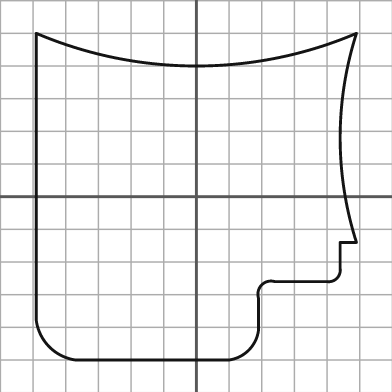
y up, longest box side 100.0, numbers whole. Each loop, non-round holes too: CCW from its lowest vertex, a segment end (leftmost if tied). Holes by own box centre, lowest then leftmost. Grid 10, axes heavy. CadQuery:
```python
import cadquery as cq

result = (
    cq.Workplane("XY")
    .moveTo(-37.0, -50.0)
    .lineTo(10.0, -50.0)
    .threePointArc((16.0, -47.0), (19.0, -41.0))
    .lineTo(19.0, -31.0)
    .threePointArc((20.0, -27.0), (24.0, -26.0))
    .lineTo(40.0, -26.0)
    .threePointArc((43.0, -25.0), (44.0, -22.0))
    .lineTo(44.0, -14.0)
    .lineTo(49.0, -14.0)
    .threePointArc((44.0, 18.0), (49.0, 50.0))
    .threePointArc((0.0, 40.0), (-49.0, 50.0))
    .lineTo(-49.0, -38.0)
    .threePointArc((-45.0, -46.0), (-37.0, -50.0))
    .close()
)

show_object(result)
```